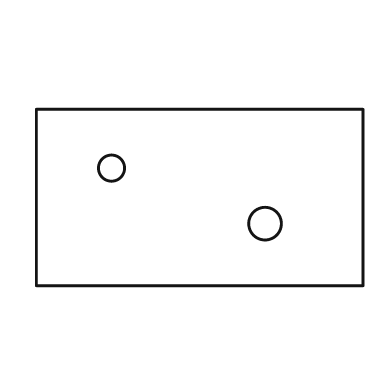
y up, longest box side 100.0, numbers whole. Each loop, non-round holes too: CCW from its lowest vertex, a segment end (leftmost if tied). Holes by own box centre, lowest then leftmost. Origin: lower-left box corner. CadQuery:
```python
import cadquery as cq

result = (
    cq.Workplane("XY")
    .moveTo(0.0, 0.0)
    .lineTo(100.0, 0.0)
    .lineTo(100.0, 54.0)
    .lineTo(0.0, 54.0)
    .close()
    .moveTo(70.0, 19.0)
    .circle(5.0)
    .moveTo(23.0, 36.0)
    .circle(4.0)
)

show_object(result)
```